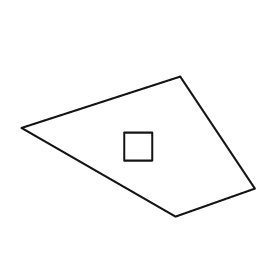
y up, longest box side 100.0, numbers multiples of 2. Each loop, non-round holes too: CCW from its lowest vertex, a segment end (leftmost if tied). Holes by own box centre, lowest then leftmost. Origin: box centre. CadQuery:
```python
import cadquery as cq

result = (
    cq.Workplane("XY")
    .moveTo(16.0, -30.0)
    .lineTo(50.0, -18.0)
    .lineTo(18.0, 30.0)
    .lineTo(-50.0, 8.0)
    .close()
    .moveTo(-6.0, -6.0)
    .lineTo(6.0, -6.0)
    .lineTo(6.0, 6.0)
    .lineTo(-6.0, 6.0)
    .close()
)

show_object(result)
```